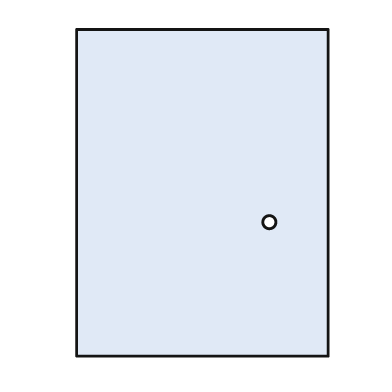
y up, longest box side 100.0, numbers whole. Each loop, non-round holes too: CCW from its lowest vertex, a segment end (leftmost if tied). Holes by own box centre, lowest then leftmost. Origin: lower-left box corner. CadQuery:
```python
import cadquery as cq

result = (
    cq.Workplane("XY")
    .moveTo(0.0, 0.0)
    .lineTo(77.0, 0.0)
    .lineTo(77.0, 100.0)
    .lineTo(0.0, 100.0)
    .close()
    .moveTo(59.0, 41.0)
    .circle(2.0)
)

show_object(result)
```